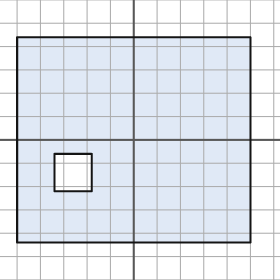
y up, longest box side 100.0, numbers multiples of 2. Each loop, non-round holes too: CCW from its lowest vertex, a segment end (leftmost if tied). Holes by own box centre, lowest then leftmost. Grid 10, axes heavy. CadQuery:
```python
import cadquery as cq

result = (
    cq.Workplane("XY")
    .moveTo(-50.0, -44.0)
    .lineTo(50.0, -44.0)
    .lineTo(50.0, 44.0)
    .lineTo(-50.0, 44.0)
    .close()
    .moveTo(-34.0, -22.0)
    .lineTo(-18.0, -22.0)
    .lineTo(-18.0, -6.0)
    .lineTo(-34.0, -6.0)
    .close()
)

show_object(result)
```